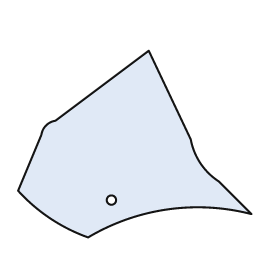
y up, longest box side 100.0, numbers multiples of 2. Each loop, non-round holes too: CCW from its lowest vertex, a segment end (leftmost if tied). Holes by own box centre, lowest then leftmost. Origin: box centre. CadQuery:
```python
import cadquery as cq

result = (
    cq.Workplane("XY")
    .moveTo(-20.0, -40.0)
    .threePointArc((14.0, -28.0), (50.0, -30.0))
    .lineTo(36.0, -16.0)
    .threePointArc((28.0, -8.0), (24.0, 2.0))
    .lineTo(6.0, 40.0)
    .lineTo(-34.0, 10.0)
    .threePointArc((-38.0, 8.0), (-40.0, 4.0))
    .lineTo(-50.0, -20.0)
    .threePointArc((-36.0, -32.0), (-20.0, -40.0))
    .close()
    .moveTo(-10.0, -24.0)
    .circle(2.0)
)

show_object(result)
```